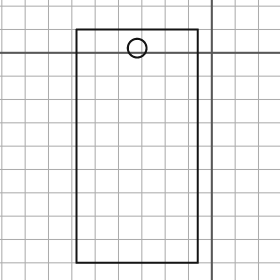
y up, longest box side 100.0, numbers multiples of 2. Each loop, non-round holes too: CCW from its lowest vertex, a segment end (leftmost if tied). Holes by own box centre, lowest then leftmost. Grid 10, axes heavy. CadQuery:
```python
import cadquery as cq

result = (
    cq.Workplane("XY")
    .moveTo(-58.0, -90.0)
    .lineTo(-6.0, -90.0)
    .lineTo(-6.0, 10.0)
    .lineTo(-58.0, 10.0)
    .close()
    .moveTo(-32.0, 2.0)
    .circle(4.0)
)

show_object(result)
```